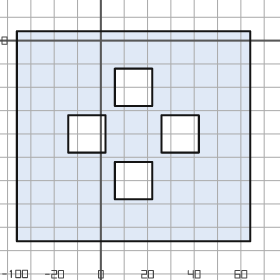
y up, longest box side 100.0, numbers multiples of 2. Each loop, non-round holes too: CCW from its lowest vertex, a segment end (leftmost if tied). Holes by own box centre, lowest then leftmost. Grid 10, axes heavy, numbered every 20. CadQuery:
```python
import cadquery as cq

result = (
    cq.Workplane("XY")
    .moveTo(-36.0, -86.0)
    .lineTo(64.0, -86.0)
    .lineTo(64.0, 4.0)
    .lineTo(-36.0, 4.0)
    .close()
    .moveTo(6.0, -68.0)
    .lineTo(22.0, -68.0)
    .lineTo(22.0, -52.0)
    .lineTo(6.0, -52.0)
    .close()
    .moveTo(-14.0, -48.0)
    .lineTo(2.0, -48.0)
    .lineTo(2.0, -32.0)
    .lineTo(-14.0, -32.0)
    .close()
    .moveTo(26.0, -48.0)
    .lineTo(42.0, -48.0)
    .lineTo(42.0, -32.0)
    .lineTo(26.0, -32.0)
    .close()
    .moveTo(6.0, -28.0)
    .lineTo(22.0, -28.0)
    .lineTo(22.0, -12.0)
    .lineTo(6.0, -12.0)
    .close()
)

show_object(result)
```